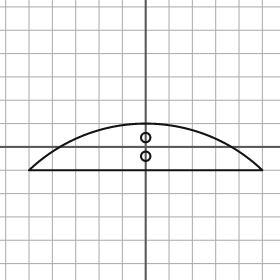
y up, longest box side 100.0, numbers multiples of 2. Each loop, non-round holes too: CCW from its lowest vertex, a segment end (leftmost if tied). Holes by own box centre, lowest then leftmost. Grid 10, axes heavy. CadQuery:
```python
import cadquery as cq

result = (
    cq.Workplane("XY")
    .moveTo(-50.0, -10.0)
    .lineTo(50.0, -10.0)
    .threePointArc((0.0, 10.0), (-50.0, -10.0))
    .close()
    .moveTo(0.0, -4.0)
    .circle(2.0)
    .moveTo(0.0, 4.0)
    .circle(2.0)
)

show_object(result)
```